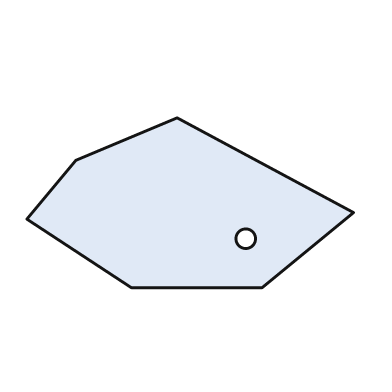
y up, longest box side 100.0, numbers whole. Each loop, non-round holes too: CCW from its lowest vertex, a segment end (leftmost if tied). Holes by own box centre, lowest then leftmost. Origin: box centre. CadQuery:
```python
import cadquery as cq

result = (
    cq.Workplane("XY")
    .moveTo(-18.0, -26.0)
    .lineTo(22.0, -26.0)
    .lineTo(50.0, -3.0)
    .lineTo(-4.0, 26.0)
    .lineTo(-35.0, 13.0)
    .lineTo(-50.0, -5.0)
    .close()
    .moveTo(17.0, -11.0)
    .circle(3.0)
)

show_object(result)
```